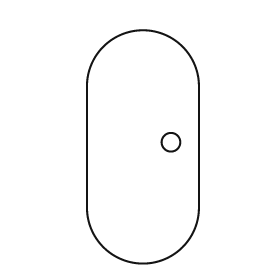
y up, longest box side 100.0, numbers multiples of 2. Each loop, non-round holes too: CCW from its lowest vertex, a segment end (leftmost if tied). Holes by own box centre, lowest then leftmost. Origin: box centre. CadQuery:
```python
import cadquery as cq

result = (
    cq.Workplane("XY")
    .moveTo(-24.0, -26.0)
    .threePointArc((0.0, -50.0), (24.0, -26.0))
    .lineTo(24.0, 26.0)
    .threePointArc((0.0, 50.0), (-24.0, 26.0))
    .close()
    .moveTo(12.0, 2.0)
    .circle(4.0)
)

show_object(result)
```